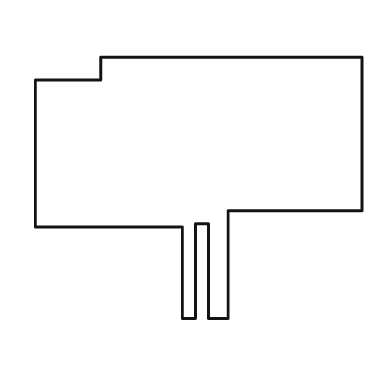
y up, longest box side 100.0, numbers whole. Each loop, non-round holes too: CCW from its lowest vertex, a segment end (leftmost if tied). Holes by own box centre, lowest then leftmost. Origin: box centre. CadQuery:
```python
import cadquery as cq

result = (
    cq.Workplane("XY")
    .moveTo(-5.0, -40.0)
    .lineTo(-1.0, -40.0)
    .lineTo(-1.0, -11.0)
    .lineTo(3.0, -11.0)
    .lineTo(3.0, -40.0)
    .lineTo(9.0, -40.0)
    .lineTo(9.0, -7.0)
    .lineTo(50.0, -7.0)
    .lineTo(50.0, 40.0)
    .lineTo(-30.0, 40.0)
    .lineTo(-30.0, 33.0)
    .lineTo(-50.0, 33.0)
    .lineTo(-50.0, -12.0)
    .lineTo(-5.0, -12.0)
    .close()
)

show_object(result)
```